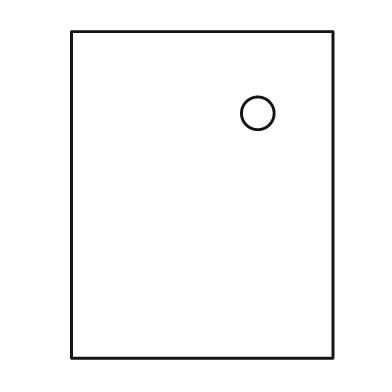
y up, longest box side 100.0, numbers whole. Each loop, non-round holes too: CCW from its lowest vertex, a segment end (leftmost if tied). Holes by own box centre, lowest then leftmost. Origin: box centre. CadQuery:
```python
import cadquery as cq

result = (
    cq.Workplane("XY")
    .moveTo(-40.0, -50.0)
    .lineTo(40.0, -50.0)
    .lineTo(40.0, 50.0)
    .lineTo(-40.0, 50.0)
    .close()
    .moveTo(17.0, 25.0)
    .circle(5.0)
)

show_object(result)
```